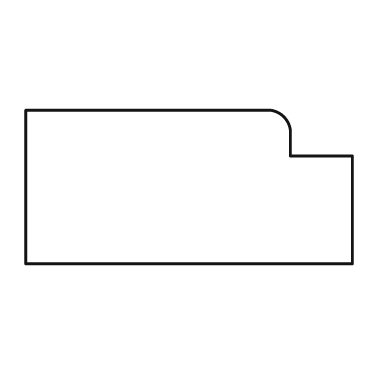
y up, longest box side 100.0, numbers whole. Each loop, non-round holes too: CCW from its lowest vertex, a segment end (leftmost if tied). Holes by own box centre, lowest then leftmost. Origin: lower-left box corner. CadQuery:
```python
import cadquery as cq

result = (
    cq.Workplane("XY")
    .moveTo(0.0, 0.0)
    .lineTo(100.0, 0.0)
    .lineTo(100.0, 33.0)
    .lineTo(81.0, 33.0)
    .lineTo(81.0, 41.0)
    .threePointArc((79.0, 45.0), (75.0, 47.0))
    .lineTo(0.0, 47.0)
    .close()
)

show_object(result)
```